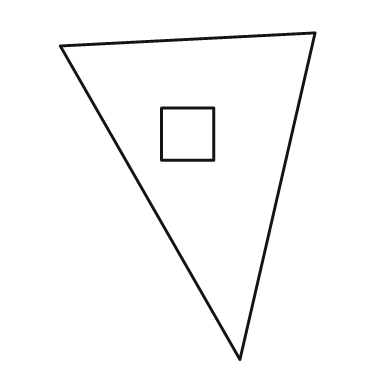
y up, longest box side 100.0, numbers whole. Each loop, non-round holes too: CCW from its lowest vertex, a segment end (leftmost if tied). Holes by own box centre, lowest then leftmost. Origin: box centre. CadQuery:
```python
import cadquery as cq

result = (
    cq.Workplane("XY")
    .moveTo(16.0, -50.0)
    .lineTo(39.0, 50.0)
    .lineTo(-39.0, 46.0)
    .close()
    .moveTo(-8.0, 11.0)
    .lineTo(8.0, 11.0)
    .lineTo(8.0, 27.0)
    .lineTo(-8.0, 27.0)
    .close()
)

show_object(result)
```